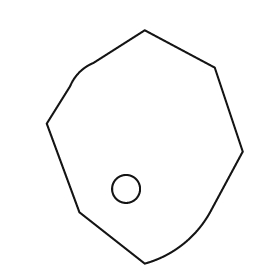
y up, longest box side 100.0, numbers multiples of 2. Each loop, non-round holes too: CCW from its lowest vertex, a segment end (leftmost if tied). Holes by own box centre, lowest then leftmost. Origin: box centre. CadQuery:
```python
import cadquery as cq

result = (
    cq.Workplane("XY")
    .moveTo(0.0, -50.0)
    .threePointArc((16.0, -42.0), (28.0, -28.0))
    .lineTo(42.0, -2.0)
    .lineTo(30.0, 34.0)
    .lineTo(0.0, 50.0)
    .lineTo(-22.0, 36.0)
    .threePointArc((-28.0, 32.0), (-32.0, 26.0))
    .lineTo(-42.0, 10.0)
    .lineTo(-28.0, -28.0)
    .close()
    .moveTo(-8.0, -18.0)
    .circle(6.0)
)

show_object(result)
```